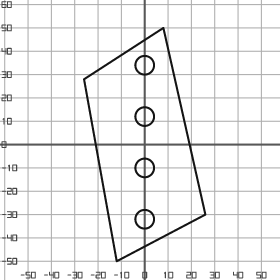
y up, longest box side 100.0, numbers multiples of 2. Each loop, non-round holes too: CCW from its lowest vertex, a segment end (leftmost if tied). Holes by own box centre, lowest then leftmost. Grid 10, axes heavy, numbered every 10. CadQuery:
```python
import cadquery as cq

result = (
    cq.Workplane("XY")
    .moveTo(-12.0, -50.0)
    .lineTo(26.0, -30.0)
    .lineTo(8.0, 50.0)
    .lineTo(-26.0, 28.0)
    .close()
    .moveTo(0.0, -32.0)
    .circle(4.0)
    .moveTo(0.0, -10.0)
    .circle(4.0)
    .moveTo(0.0, 12.0)
    .circle(4.0)
    .moveTo(0.0, 34.0)
    .circle(4.0)
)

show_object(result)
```